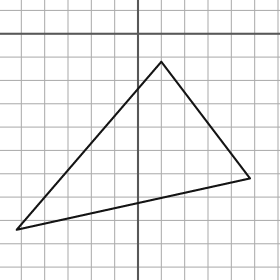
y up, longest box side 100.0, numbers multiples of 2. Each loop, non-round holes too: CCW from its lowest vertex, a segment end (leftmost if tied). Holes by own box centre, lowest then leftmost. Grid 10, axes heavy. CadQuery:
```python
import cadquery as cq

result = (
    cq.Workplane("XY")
    .moveTo(-52.0, -84.0)
    .lineTo(48.0, -62.0)
    .lineTo(10.0, -12.0)
    .close()
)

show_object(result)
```